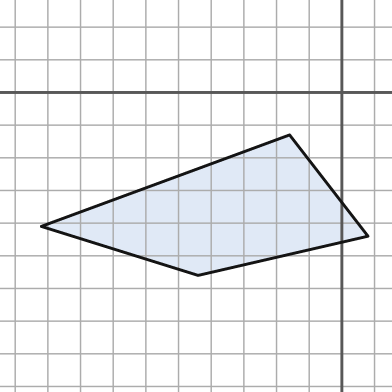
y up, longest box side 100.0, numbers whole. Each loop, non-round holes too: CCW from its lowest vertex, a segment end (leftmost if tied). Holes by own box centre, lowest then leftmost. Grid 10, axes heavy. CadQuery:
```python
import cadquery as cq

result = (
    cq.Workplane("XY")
    .moveTo(-44.0, -56.0)
    .lineTo(8.0, -44.0)
    .lineTo(-16.0, -13.0)
    .lineTo(-92.0, -41.0)
    .close()
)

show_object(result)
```